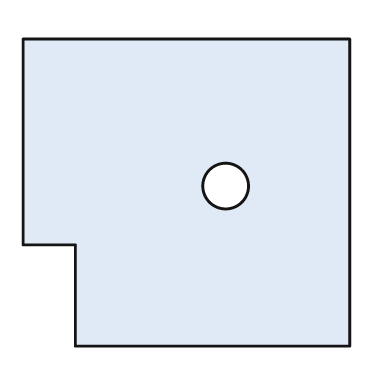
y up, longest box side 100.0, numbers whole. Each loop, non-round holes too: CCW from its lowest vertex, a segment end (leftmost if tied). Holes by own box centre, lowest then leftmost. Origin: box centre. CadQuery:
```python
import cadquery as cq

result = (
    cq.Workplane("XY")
    .moveTo(-34.0, -47.0)
    .lineTo(50.0, -47.0)
    .lineTo(50.0, 47.0)
    .lineTo(-50.0, 47.0)
    .lineTo(-50.0, -16.0)
    .lineTo(-34.0, -16.0)
    .close()
    .moveTo(12.0, 2.0)
    .circle(7.0)
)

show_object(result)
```